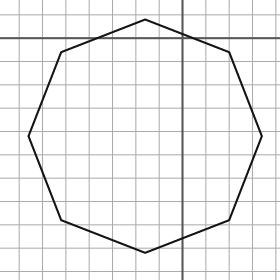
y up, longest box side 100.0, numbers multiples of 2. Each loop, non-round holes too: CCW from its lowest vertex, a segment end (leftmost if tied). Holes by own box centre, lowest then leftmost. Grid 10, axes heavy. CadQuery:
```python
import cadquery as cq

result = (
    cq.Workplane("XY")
    .moveTo(-16.0, -92.0)
    .lineTo(20.0, -78.0)
    .lineTo(34.0, -42.0)
    .lineTo(20.0, -6.0)
    .lineTo(-16.0, 8.0)
    .lineTo(-52.0, -6.0)
    .lineTo(-66.0, -42.0)
    .lineTo(-52.0, -78.0)
    .close()
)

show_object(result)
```